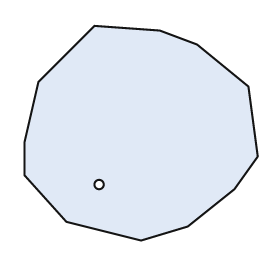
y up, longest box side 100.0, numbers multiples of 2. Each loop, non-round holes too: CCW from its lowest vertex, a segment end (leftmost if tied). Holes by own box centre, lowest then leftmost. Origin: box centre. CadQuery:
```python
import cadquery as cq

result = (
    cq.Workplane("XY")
    .moveTo(0.0, -46.0)
    .lineTo(20.0, -40.0)
    .lineTo(40.0, -24.0)
    .lineTo(50.0, -10.0)
    .lineTo(46.0, 20.0)
    .lineTo(24.0, 38.0)
    .lineTo(8.0, 44.0)
    .lineTo(-20.0, 46.0)
    .lineTo(-44.0, 22.0)
    .lineTo(-50.0, -4.0)
    .lineTo(-50.0, -18.0)
    .lineTo(-32.0, -38.0)
    .close()
    .moveTo(-18.0, -22.0)
    .circle(2.0)
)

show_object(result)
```